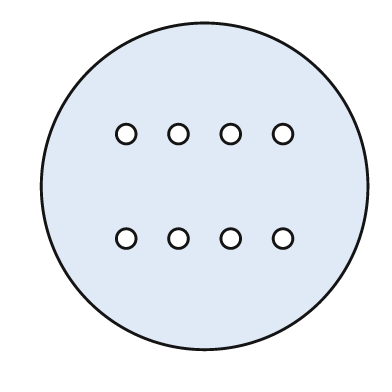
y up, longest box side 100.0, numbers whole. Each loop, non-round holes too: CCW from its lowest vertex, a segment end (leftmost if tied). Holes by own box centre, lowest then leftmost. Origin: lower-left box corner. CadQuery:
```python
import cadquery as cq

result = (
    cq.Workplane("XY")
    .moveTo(50.0, 50.0)
    .circle(50.0)
    .moveTo(26.0, 34.0)
    .circle(3.0)
    .moveTo(42.0, 34.0)
    .circle(3.0)
    .moveTo(58.0, 34.0)
    .circle(3.0)
    .moveTo(74.0, 34.0)
    .circle(3.0)
    .moveTo(26.0, 66.0)
    .circle(3.0)
    .moveTo(42.0, 66.0)
    .circle(3.0)
    .moveTo(58.0, 66.0)
    .circle(3.0)
    .moveTo(74.0, 66.0)
    .circle(3.0)
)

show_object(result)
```